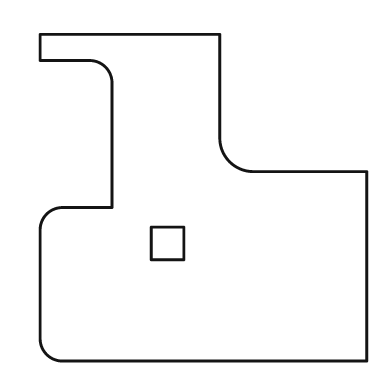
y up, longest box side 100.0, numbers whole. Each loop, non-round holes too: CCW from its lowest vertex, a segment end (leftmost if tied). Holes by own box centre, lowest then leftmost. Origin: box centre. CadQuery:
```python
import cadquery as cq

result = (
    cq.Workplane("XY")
    .moveTo(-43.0, -50.0)
    .lineTo(50.0, -50.0)
    .lineTo(50.0, 8.0)
    .lineTo(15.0, 8.0)
    .threePointArc((8.0, 11.0), (5.0, 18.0))
    .lineTo(5.0, 50.0)
    .lineTo(-50.0, 50.0)
    .lineTo(-50.0, 42.0)
    .lineTo(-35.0, 42.0)
    .threePointArc((-30.0, 40.0), (-28.0, 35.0))
    .lineTo(-28.0, -3.0)
    .lineTo(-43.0, -3.0)
    .threePointArc((-48.0, -5.0), (-50.0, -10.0))
    .lineTo(-50.0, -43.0)
    .threePointArc((-48.0, -48.0), (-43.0, -50.0))
    .close()
    .moveTo(-16.0, -19.0)
    .lineTo(-6.0, -19.0)
    .lineTo(-6.0, -9.0)
    .lineTo(-16.0, -9.0)
    .close()
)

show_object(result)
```